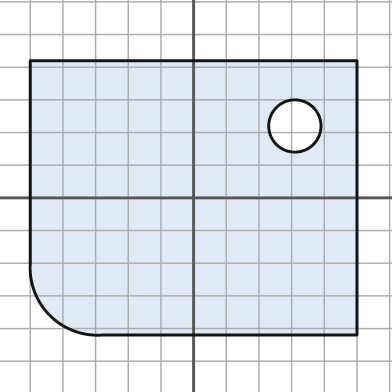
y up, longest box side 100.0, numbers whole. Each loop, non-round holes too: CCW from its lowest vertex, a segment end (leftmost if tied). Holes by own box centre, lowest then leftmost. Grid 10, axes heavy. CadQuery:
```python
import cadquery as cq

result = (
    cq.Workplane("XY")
    .moveTo(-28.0, -42.0)
    .lineTo(50.0, -42.0)
    .lineTo(50.0, 42.0)
    .lineTo(-50.0, 42.0)
    .lineTo(-50.0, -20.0)
    .threePointArc((-44.0, -36.0), (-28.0, -42.0))
    .close()
    .moveTo(31.0, 22.0)
    .circle(8.0)
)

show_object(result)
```